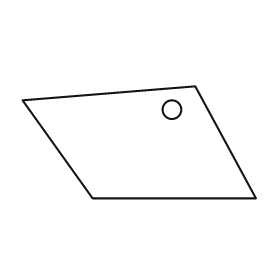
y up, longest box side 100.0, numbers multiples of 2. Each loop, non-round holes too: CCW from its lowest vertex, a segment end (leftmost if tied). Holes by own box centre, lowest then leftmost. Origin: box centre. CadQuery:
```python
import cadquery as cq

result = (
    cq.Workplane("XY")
    .moveTo(-20.0, -24.0)
    .lineTo(50.0, -24.0)
    .lineTo(24.0, 24.0)
    .lineTo(-50.0, 18.0)
    .close()
    .moveTo(14.0, 14.0)
    .circle(4.0)
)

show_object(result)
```